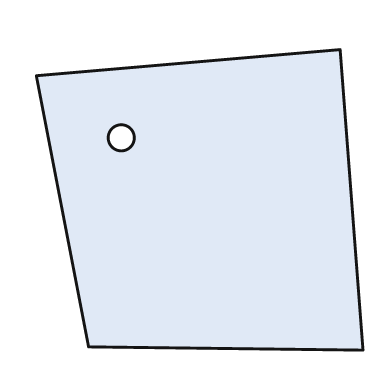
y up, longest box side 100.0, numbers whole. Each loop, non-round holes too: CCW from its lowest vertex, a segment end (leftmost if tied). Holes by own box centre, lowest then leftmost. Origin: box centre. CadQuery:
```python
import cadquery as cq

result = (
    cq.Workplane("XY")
    .moveTo(50.0, -46.0)
    .lineTo(43.0, 46.0)
    .lineTo(-50.0, 38.0)
    .lineTo(-34.0, -45.0)
    .close()
    .moveTo(-24.0, 19.0)
    .circle(4.0)
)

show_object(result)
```